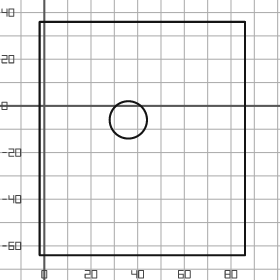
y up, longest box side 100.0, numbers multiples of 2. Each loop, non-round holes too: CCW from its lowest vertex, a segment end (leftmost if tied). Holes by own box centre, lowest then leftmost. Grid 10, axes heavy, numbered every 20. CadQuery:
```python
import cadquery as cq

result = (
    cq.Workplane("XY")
    .moveTo(-2.0, -64.0)
    .lineTo(86.0, -64.0)
    .lineTo(86.0, 36.0)
    .lineTo(-2.0, 36.0)
    .close()
    .moveTo(36.0, -6.0)
    .circle(8.0)
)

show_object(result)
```